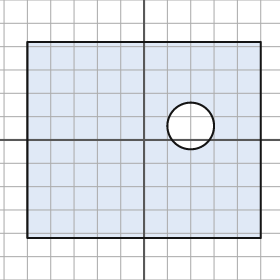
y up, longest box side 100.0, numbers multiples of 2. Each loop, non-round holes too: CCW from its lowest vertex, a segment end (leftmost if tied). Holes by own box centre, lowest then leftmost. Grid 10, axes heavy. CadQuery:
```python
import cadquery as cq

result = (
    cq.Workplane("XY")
    .moveTo(-50.0, -42.0)
    .lineTo(50.0, -42.0)
    .lineTo(50.0, 42.0)
    .lineTo(-50.0, 42.0)
    .close()
    .moveTo(20.0, 6.0)
    .circle(10.0)
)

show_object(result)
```